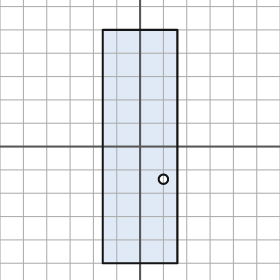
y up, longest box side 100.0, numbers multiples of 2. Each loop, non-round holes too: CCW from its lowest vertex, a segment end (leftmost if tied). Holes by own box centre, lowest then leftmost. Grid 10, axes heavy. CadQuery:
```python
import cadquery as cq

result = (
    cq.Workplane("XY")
    .moveTo(-16.0, -50.0)
    .lineTo(16.0, -50.0)
    .lineTo(16.0, 50.0)
    .lineTo(-16.0, 50.0)
    .close()
    .moveTo(10.0, -14.0)
    .circle(2.0)
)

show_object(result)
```